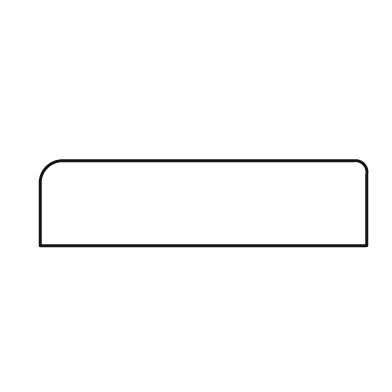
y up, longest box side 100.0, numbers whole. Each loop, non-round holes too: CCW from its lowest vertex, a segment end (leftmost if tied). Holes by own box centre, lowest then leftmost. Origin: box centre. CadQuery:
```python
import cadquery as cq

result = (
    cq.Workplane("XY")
    .moveTo(-50.0, -13.0)
    .lineTo(50.0, -13.0)
    .lineTo(50.0, 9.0)
    .threePointArc((49.0, 12.0), (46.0, 13.0))
    .lineTo(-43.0, 13.0)
    .threePointArc((-48.0, 11.0), (-50.0, 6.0))
    .close()
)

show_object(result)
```